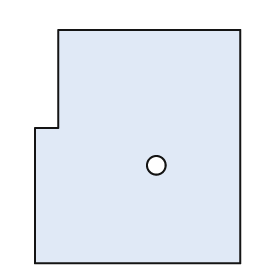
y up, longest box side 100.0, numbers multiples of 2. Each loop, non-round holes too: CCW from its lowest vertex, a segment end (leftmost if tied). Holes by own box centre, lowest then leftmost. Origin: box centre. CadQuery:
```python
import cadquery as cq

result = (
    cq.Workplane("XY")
    .moveTo(-44.0, -50.0)
    .lineTo(44.0, -50.0)
    .lineTo(44.0, 50.0)
    .lineTo(-34.0, 50.0)
    .lineTo(-34.0, 8.0)
    .lineTo(-44.0, 8.0)
    .close()
    .moveTo(8.0, -8.0)
    .circle(4.0)
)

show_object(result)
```